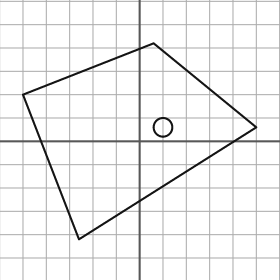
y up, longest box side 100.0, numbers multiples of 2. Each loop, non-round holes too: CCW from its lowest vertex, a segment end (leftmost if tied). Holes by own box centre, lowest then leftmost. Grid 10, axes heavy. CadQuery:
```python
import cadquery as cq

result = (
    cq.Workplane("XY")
    .moveTo(-26.0, -42.0)
    .lineTo(50.0, 6.0)
    .lineTo(6.0, 42.0)
    .lineTo(-50.0, 20.0)
    .close()
    .moveTo(10.0, 6.0)
    .circle(4.0)
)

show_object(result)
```